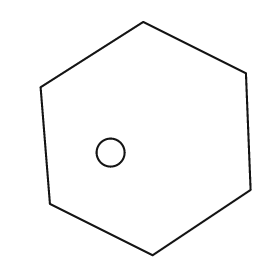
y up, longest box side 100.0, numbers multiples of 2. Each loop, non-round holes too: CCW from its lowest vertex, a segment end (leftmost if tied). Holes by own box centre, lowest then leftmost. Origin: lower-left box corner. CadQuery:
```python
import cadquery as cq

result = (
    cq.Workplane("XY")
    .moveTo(48.0, 0.0)
    .lineTo(90.0, 28.0)
    .lineTo(88.0, 78.0)
    .lineTo(44.0, 100.0)
    .lineTo(0.0, 72.0)
    .lineTo(4.0, 22.0)
    .close()
    .moveTo(30.0, 44.0)
    .circle(6.0)
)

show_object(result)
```